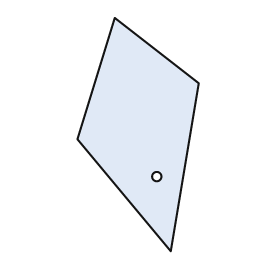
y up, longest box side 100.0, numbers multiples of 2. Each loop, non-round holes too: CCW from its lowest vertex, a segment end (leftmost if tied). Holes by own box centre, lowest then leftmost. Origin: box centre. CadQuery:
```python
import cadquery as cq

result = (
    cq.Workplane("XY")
    .moveTo(14.0, -50.0)
    .lineTo(26.0, 22.0)
    .lineTo(-10.0, 50.0)
    .lineTo(-26.0, -2.0)
    .close()
    .moveTo(8.0, -18.0)
    .circle(2.0)
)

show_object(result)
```